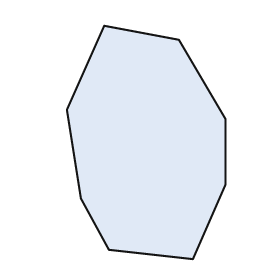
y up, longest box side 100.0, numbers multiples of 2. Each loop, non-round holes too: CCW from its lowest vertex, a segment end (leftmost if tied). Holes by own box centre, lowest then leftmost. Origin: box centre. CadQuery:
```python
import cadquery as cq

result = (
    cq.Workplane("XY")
    .moveTo(20.0, -50.0)
    .lineTo(34.0, -18.0)
    .lineTo(34.0, 10.0)
    .lineTo(14.0, 44.0)
    .lineTo(-18.0, 50.0)
    .lineTo(-34.0, 14.0)
    .lineTo(-28.0, -24.0)
    .lineTo(-16.0, -46.0)
    .close()
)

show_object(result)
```